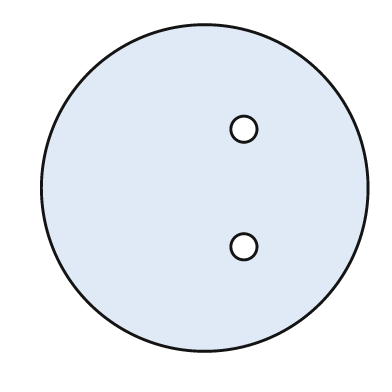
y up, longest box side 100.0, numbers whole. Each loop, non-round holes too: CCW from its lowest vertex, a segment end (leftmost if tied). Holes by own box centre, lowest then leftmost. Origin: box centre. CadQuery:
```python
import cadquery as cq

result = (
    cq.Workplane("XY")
    .moveTo(0.0, 0.0)
    .circle(50.0)
    .moveTo(12.0, -18.0)
    .circle(4.0)
    .moveTo(12.0, 18.0)
    .circle(4.0)
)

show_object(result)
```